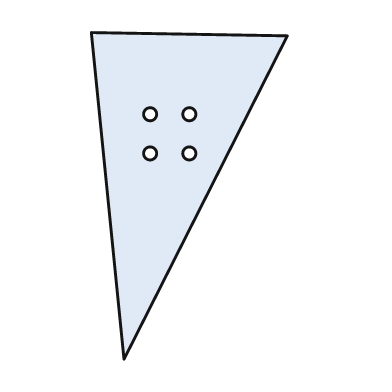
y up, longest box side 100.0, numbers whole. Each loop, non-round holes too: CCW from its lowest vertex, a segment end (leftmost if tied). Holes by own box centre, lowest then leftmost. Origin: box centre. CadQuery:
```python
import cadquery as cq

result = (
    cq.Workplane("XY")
    .moveTo(-20.0, -50.0)
    .lineTo(30.0, 49.0)
    .lineTo(-30.0, 50.0)
    .close()
    .moveTo(-12.0, 13.0)
    .circle(2.0)
    .moveTo(0.0, 13.0)
    .circle(2.0)
    .moveTo(-12.0, 25.0)
    .circle(2.0)
    .moveTo(0.0, 25.0)
    .circle(2.0)
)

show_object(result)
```